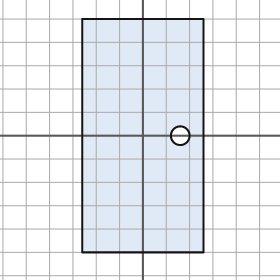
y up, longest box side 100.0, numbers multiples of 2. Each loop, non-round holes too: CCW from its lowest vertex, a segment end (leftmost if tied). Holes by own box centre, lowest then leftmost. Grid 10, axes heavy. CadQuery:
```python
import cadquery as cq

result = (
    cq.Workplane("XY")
    .moveTo(-26.0, -50.0)
    .lineTo(26.0, -50.0)
    .lineTo(26.0, 50.0)
    .lineTo(-26.0, 50.0)
    .close()
    .moveTo(16.0, 0.0)
    .circle(4.0)
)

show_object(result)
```